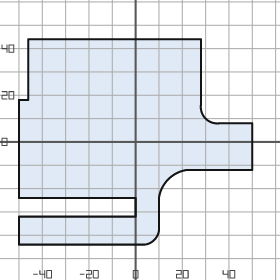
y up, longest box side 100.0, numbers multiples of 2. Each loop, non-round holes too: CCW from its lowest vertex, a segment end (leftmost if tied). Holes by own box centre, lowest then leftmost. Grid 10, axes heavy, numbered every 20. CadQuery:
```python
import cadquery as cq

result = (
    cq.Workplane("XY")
    .moveTo(-50.0, -44.0)
    .lineTo(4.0, -44.0)
    .threePointArc((8.0, -42.0), (10.0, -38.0))
    .lineTo(10.0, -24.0)
    .threePointArc((14.0, -16.0), (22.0, -12.0))
    .lineTo(50.0, -12.0)
    .lineTo(50.0, 8.0)
    .lineTo(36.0, 8.0)
    .threePointArc((30.0, 10.0), (28.0, 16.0))
    .lineTo(28.0, 44.0)
    .lineTo(-46.0, 44.0)
    .lineTo(-46.0, 18.0)
    .lineTo(-50.0, 18.0)
    .lineTo(-50.0, -24.0)
    .lineTo(0.0, -24.0)
    .lineTo(0.0, -32.0)
    .lineTo(-50.0, -32.0)
    .close()
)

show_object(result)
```